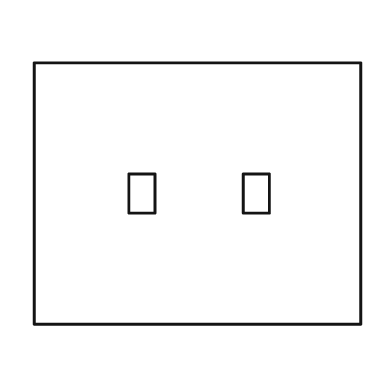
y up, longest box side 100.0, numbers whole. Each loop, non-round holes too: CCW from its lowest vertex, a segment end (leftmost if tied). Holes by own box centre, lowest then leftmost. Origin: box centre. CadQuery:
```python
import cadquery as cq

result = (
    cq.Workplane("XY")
    .moveTo(-50.0, -40.0)
    .lineTo(50.0, -40.0)
    .lineTo(50.0, 40.0)
    .lineTo(-50.0, 40.0)
    .close()
    .moveTo(-21.0, -6.0)
    .lineTo(-13.0, -6.0)
    .lineTo(-13.0, 6.0)
    .lineTo(-21.0, 6.0)
    .close()
    .moveTo(14.0, -6.0)
    .lineTo(22.0, -6.0)
    .lineTo(22.0, 6.0)
    .lineTo(14.0, 6.0)
    .close()
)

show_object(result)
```